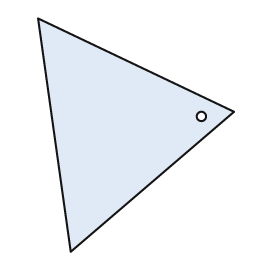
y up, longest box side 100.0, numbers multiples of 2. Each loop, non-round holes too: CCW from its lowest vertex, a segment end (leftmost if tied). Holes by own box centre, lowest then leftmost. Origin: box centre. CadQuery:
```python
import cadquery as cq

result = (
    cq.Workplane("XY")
    .moveTo(-28.0, -50.0)
    .lineTo(42.0, 10.0)
    .lineTo(-42.0, 50.0)
    .close()
    .moveTo(28.0, 8.0)
    .circle(2.0)
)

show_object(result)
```